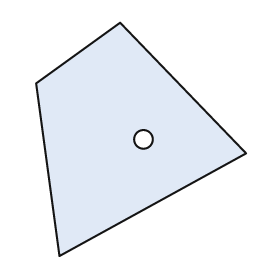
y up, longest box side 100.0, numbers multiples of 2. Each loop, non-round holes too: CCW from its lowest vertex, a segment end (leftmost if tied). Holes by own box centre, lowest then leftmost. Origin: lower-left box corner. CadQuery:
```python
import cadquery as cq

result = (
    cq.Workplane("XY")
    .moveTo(10.0, 0.0)
    .lineTo(90.0, 44.0)
    .lineTo(36.0, 100.0)
    .lineTo(0.0, 74.0)
    .close()
    .moveTo(46.0, 50.0)
    .circle(4.0)
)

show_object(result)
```